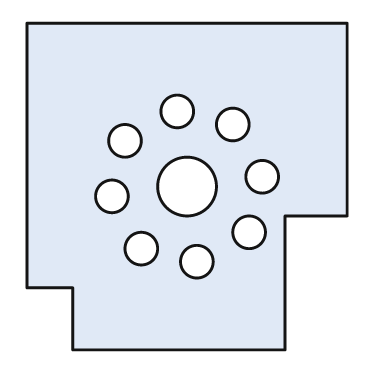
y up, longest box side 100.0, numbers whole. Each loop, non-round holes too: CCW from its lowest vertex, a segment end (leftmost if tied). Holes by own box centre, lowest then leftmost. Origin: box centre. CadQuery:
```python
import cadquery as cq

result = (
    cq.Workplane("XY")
    .moveTo(-35.0, -50.0)
    .lineTo(30.0, -50.0)
    .lineTo(30.0, -9.0)
    .lineTo(49.0, -9.0)
    .lineTo(49.0, 50.0)
    .lineTo(-49.0, 50.0)
    .lineTo(-49.0, -31.0)
    .lineTo(-35.0, -31.0)
    .close()
    .moveTo(3.0, -23.0)
    .circle(5.0)
    .moveTo(-14.0, -19.0)
    .circle(5.0)
    .moveTo(19.0, -14.0)
    .circle(5.0)
    .moveTo(-23.0, -3.0)
    .circle(5.0)
    .moveTo(0.0, 0.0)
    .circle(9.0)
    .moveTo(23.0, 3.0)
    .circle(5.0)
    .moveTo(-19.0, 14.0)
    .circle(5.0)
    .moveTo(14.0, 19.0)
    .circle(5.0)
    .moveTo(-3.0, 23.0)
    .circle(5.0)
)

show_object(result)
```